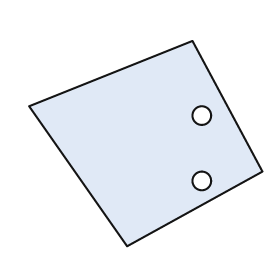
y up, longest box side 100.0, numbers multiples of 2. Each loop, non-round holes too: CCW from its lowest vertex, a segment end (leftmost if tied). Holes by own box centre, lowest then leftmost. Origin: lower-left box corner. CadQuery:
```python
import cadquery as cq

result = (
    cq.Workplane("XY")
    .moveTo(42.0, 0.0)
    .lineTo(100.0, 32.0)
    .lineTo(70.0, 88.0)
    .lineTo(0.0, 60.0)
    .close()
    .moveTo(74.0, 28.0)
    .circle(4.0)
    .moveTo(74.0, 56.0)
    .circle(4.0)
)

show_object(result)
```